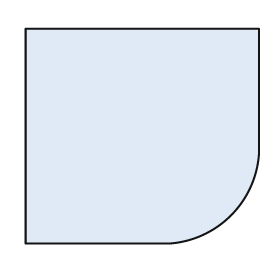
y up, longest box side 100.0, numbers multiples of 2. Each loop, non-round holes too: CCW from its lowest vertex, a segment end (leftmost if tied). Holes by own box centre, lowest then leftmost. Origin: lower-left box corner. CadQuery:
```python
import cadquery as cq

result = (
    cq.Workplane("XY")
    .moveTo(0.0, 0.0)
    .lineTo(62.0, 0.0)
    .threePointArc((88.0, 12.0), (100.0, 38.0))
    .lineTo(100.0, 92.0)
    .lineTo(0.0, 92.0)
    .close()
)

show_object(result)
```